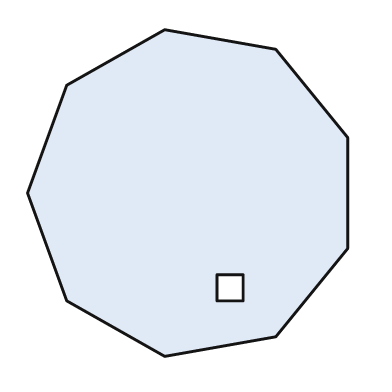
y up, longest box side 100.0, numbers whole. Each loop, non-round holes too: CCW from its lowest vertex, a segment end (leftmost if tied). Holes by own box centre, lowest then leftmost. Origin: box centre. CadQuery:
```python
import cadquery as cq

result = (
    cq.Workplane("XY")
    .moveTo(-7.0, -50.0)
    .lineTo(27.0, -44.0)
    .lineTo(49.0, -17.0)
    .lineTo(49.0, 17.0)
    .lineTo(27.0, 44.0)
    .lineTo(-7.0, 50.0)
    .lineTo(-37.0, 33.0)
    .lineTo(-49.0, 0.0)
    .lineTo(-37.0, -33.0)
    .close()
    .moveTo(9.0, -33.0)
    .lineTo(17.0, -33.0)
    .lineTo(17.0, -25.0)
    .lineTo(9.0, -25.0)
    .close()
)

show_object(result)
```